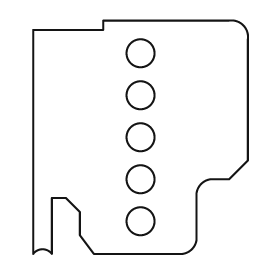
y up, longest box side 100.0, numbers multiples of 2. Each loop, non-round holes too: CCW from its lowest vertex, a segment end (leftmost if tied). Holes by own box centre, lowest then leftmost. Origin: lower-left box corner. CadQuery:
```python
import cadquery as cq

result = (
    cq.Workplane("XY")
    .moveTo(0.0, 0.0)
    .threePointArc((4.0, 2.0), (8.0, 0.0))
    .lineTo(8.0, 24.0)
    .lineTo(14.0, 24.0)
    .lineTo(20.0, 18.0)
    .lineTo(20.0, 8.0)
    .lineTo(26.0, 0.0)
    .lineTo(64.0, 0.0)
    .threePointArc((68.0, 2.0), (70.0, 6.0))
    .lineTo(70.0, 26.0)
    .threePointArc((72.0, 30.0), (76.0, 32.0))
    .lineTo(84.0, 32.0)
    .lineTo(92.0, 40.0)
    .lineTo(92.0, 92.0)
    .threePointArc((90.0, 98.0), (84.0, 100.0))
    .lineTo(30.0, 100.0)
    .lineTo(30.0, 96.0)
    .lineTo(0.0, 96.0)
    .close()
    .moveTo(46.0, 14.0)
    .circle(6.0)
    .moveTo(46.0, 32.0)
    .circle(6.0)
    .moveTo(46.0, 50.0)
    .circle(6.0)
    .moveTo(46.0, 68.0)
    .circle(6.0)
    .moveTo(46.0, 86.0)
    .circle(6.0)
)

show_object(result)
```